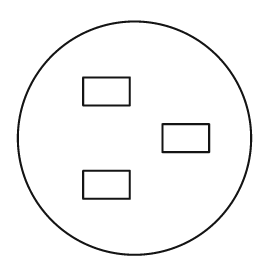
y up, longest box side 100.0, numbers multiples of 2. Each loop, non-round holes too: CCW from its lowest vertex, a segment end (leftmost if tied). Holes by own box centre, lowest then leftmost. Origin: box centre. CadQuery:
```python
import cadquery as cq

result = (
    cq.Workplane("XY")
    .moveTo(0.0, 0.0)
    .circle(50.0)
    .moveTo(-22.0, -26.0)
    .lineTo(-2.0, -26.0)
    .lineTo(-2.0, -14.0)
    .lineTo(-22.0, -14.0)
    .close()
    .moveTo(12.0, -6.0)
    .lineTo(32.0, -6.0)
    .lineTo(32.0, 6.0)
    .lineTo(12.0, 6.0)
    .close()
    .moveTo(-22.0, 14.0)
    .lineTo(-2.0, 14.0)
    .lineTo(-2.0, 26.0)
    .lineTo(-22.0, 26.0)
    .close()
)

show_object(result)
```